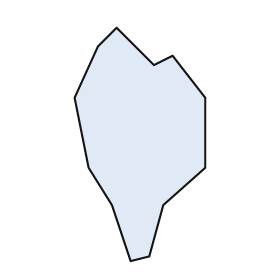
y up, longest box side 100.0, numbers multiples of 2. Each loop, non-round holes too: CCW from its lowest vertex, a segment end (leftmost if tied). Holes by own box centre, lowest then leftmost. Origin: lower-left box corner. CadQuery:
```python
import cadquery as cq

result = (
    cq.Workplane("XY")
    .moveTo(24.0, 0.0)
    .lineTo(32.0, 2.0)
    .lineTo(38.0, 24.0)
    .lineTo(56.0, 40.0)
    .lineTo(56.0, 70.0)
    .lineTo(42.0, 88.0)
    .lineTo(34.0, 84.0)
    .lineTo(18.0, 100.0)
    .lineTo(10.0, 92.0)
    .lineTo(0.0, 70.0)
    .lineTo(6.0, 40.0)
    .lineTo(16.0, 24.0)
    .close()
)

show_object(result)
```